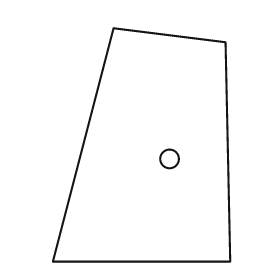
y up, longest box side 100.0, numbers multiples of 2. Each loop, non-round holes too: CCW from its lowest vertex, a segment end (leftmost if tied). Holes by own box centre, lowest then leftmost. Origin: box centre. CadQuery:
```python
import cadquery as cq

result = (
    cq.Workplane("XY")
    .moveTo(-38.0, -50.0)
    .lineTo(38.0, -50.0)
    .lineTo(36.0, 44.0)
    .lineTo(-12.0, 50.0)
    .close()
    .moveTo(12.0, -6.0)
    .circle(4.0)
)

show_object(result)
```